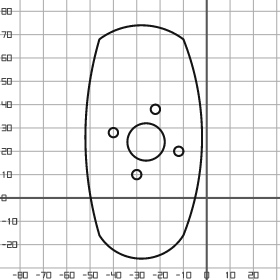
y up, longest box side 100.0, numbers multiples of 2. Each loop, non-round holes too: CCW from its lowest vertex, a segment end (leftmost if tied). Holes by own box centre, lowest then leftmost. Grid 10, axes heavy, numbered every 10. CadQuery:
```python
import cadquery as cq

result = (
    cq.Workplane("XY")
    .moveTo(-46.0, -16.0)
    .threePointArc((-28.0, -26.0), (-10.0, -16.0))
    .threePointArc((-2.0, 26.0), (-10.0, 68.0))
    .threePointArc((-28.0, 74.0), (-46.0, 68.0))
    .threePointArc((-52.0, 26.0), (-46.0, -16.0))
    .close()
    .moveTo(-30.0, 10.0)
    .circle(2.0)
    .moveTo(-12.0, 20.0)
    .circle(2.0)
    .moveTo(-26.0, 24.0)
    .circle(8.0)
    .moveTo(-40.0, 28.0)
    .circle(2.0)
    .moveTo(-22.0, 38.0)
    .circle(2.0)
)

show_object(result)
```